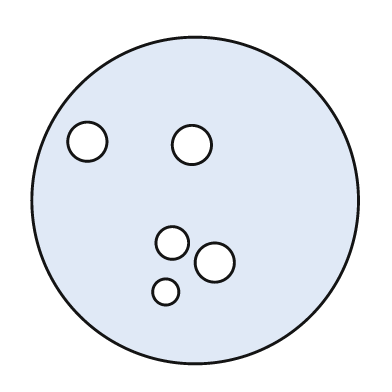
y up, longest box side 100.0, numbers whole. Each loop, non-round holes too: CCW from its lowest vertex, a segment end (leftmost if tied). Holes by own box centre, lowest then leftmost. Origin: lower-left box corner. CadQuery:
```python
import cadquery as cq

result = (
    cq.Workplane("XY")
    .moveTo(50.0, 50.0)
    .circle(50.0)
    .moveTo(41.0, 22.0)
    .circle(4.0)
    .moveTo(56.0, 31.0)
    .circle(6.0)
    .moveTo(43.0, 37.0)
    .circle(5.0)
    .moveTo(49.0, 67.0)
    .circle(6.0)
    .moveTo(17.0, 68.0)
    .circle(6.0)
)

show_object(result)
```